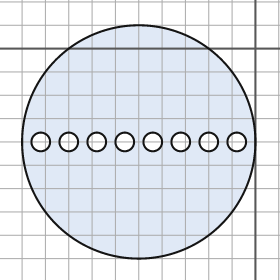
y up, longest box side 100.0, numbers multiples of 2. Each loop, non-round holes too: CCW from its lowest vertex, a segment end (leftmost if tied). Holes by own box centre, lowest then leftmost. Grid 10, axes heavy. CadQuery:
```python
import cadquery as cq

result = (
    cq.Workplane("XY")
    .moveTo(-50.0, -40.0)
    .circle(50.0)
    .moveTo(-92.0, -40.0)
    .circle(4.0)
    .moveTo(-80.0, -40.0)
    .circle(4.0)
    .moveTo(-68.0, -40.0)
    .circle(4.0)
    .moveTo(-56.0, -40.0)
    .circle(4.0)
    .moveTo(-44.0, -40.0)
    .circle(4.0)
    .moveTo(-32.0, -40.0)
    .circle(4.0)
    .moveTo(-20.0, -40.0)
    .circle(4.0)
    .moveTo(-8.0, -40.0)
    .circle(4.0)
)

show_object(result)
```